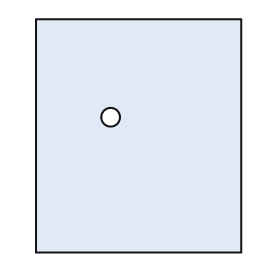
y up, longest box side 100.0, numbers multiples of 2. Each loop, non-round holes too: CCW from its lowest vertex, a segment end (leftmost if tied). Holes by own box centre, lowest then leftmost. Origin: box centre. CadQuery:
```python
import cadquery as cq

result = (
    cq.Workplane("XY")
    .moveTo(-44.0, -50.0)
    .lineTo(44.0, -50.0)
    .lineTo(44.0, 50.0)
    .lineTo(-44.0, 50.0)
    .close()
    .moveTo(-12.0, 8.0)
    .circle(4.0)
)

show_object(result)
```